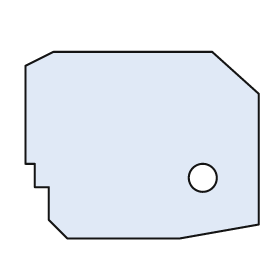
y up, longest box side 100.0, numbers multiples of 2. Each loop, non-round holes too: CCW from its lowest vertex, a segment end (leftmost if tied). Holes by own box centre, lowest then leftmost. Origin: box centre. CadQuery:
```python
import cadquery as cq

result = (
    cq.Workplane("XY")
    .moveTo(-32.0, -40.0)
    .lineTo(16.0, -40.0)
    .lineTo(50.0, -34.0)
    .lineTo(50.0, 22.0)
    .lineTo(30.0, 40.0)
    .lineTo(-38.0, 40.0)
    .lineTo(-50.0, 34.0)
    .lineTo(-50.0, -8.0)
    .lineTo(-46.0, -8.0)
    .lineTo(-46.0, -18.0)
    .lineTo(-40.0, -18.0)
    .lineTo(-40.0, -32.0)
    .close()
    .moveTo(26.0, -14.0)
    .circle(6.0)
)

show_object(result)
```